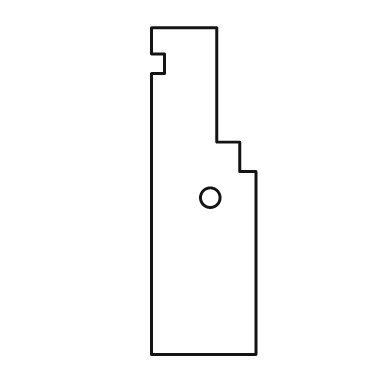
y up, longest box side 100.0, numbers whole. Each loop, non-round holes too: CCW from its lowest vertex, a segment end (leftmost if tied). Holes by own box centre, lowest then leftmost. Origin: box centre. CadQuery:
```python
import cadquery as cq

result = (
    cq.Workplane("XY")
    .moveTo(-16.0, -50.0)
    .lineTo(16.0, -50.0)
    .lineTo(16.0, 6.0)
    .lineTo(11.0, 6.0)
    .lineTo(11.0, 15.0)
    .lineTo(4.0, 15.0)
    .lineTo(4.0, 50.0)
    .lineTo(-16.0, 50.0)
    .lineTo(-16.0, 42.0)
    .lineTo(-12.0, 42.0)
    .lineTo(-12.0, 36.0)
    .lineTo(-16.0, 36.0)
    .close()
    .moveTo(2.0, -2.0)
    .circle(3.0)
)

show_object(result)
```